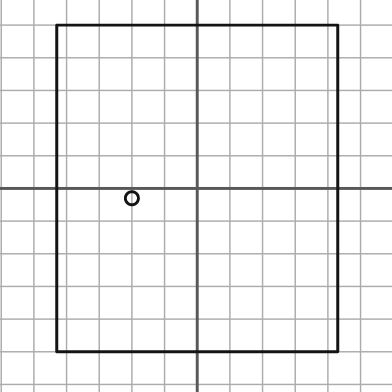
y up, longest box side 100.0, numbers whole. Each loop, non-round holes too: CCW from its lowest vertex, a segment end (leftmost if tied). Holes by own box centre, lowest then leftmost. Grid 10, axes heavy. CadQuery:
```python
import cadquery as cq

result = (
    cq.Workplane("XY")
    .moveTo(-43.0, -50.0)
    .lineTo(43.0, -50.0)
    .lineTo(43.0, 50.0)
    .lineTo(-43.0, 50.0)
    .close()
    .moveTo(-20.0, -3.0)
    .circle(2.0)
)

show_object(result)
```